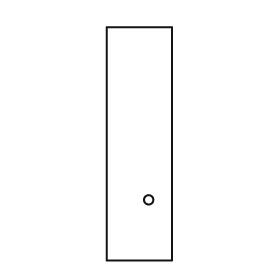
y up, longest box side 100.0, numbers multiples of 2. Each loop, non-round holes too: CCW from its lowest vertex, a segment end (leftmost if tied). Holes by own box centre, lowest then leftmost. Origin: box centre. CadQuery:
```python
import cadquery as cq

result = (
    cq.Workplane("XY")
    .moveTo(-14.0, -50.0)
    .lineTo(14.0, -50.0)
    .lineTo(14.0, 50.0)
    .lineTo(-14.0, 50.0)
    .close()
    .moveTo(4.0, -24.0)
    .circle(2.0)
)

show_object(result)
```